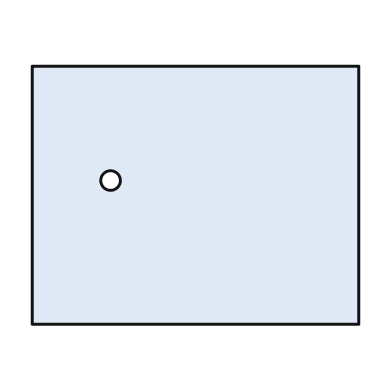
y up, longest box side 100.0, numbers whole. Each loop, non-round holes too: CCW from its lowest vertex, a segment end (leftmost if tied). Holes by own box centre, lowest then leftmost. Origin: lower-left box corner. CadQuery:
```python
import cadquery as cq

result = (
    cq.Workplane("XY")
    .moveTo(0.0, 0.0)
    .lineTo(100.0, 0.0)
    .lineTo(100.0, 79.0)
    .lineTo(0.0, 79.0)
    .close()
    .moveTo(24.0, 44.0)
    .circle(3.0)
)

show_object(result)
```